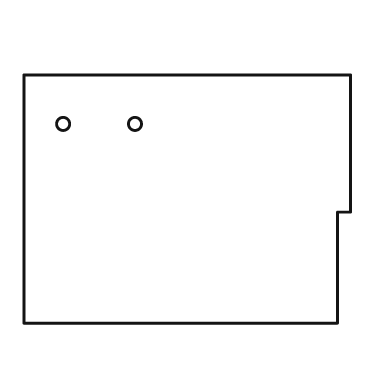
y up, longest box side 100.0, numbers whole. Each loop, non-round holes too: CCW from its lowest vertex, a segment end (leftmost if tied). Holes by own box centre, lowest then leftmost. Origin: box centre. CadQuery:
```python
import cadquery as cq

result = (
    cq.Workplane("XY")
    .moveTo(-50.0, -38.0)
    .lineTo(46.0, -38.0)
    .lineTo(46.0, -4.0)
    .lineTo(50.0, -4.0)
    .lineTo(50.0, 38.0)
    .lineTo(-50.0, 38.0)
    .close()
    .moveTo(-38.0, 23.0)
    .circle(2.0)
    .moveTo(-16.0, 23.0)
    .circle(2.0)
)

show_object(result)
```